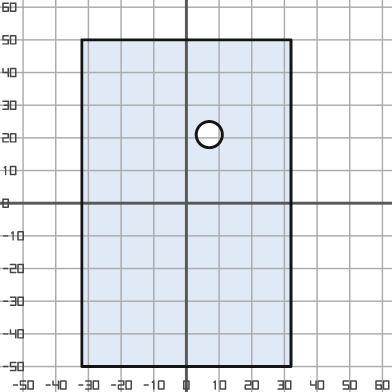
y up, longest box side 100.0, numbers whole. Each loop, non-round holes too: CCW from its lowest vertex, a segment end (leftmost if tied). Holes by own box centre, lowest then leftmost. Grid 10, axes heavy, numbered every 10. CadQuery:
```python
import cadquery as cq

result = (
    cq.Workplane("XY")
    .moveTo(-32.0, -50.0)
    .lineTo(32.0, -50.0)
    .lineTo(32.0, 50.0)
    .lineTo(-32.0, 50.0)
    .close()
    .moveTo(7.0, 21.0)
    .circle(4.0)
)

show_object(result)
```